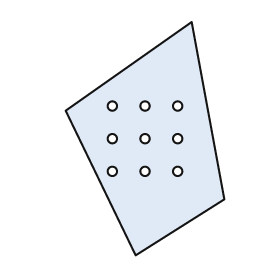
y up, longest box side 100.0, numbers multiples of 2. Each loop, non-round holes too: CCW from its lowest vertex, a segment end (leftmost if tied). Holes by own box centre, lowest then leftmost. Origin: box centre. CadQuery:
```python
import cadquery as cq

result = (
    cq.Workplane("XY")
    .moveTo(-4.0, -50.0)
    .lineTo(34.0, -26.0)
    .lineTo(20.0, 50.0)
    .lineTo(-34.0, 12.0)
    .close()
    .moveTo(-14.0, -14.0)
    .circle(2.0)
    .moveTo(0.0, -14.0)
    .circle(2.0)
    .moveTo(14.0, -14.0)
    .circle(2.0)
    .moveTo(-14.0, 0.0)
    .circle(2.0)
    .moveTo(0.0, 0.0)
    .circle(2.0)
    .moveTo(14.0, 0.0)
    .circle(2.0)
    .moveTo(-14.0, 14.0)
    .circle(2.0)
    .moveTo(0.0, 14.0)
    .circle(2.0)
    .moveTo(14.0, 14.0)
    .circle(2.0)
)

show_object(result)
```